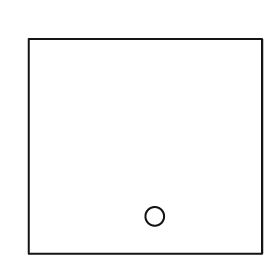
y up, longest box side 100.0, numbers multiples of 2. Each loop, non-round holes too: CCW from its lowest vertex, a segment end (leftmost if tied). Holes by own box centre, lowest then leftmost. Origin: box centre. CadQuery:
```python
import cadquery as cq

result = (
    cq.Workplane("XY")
    .moveTo(-50.0, -46.0)
    .lineTo(50.0, -46.0)
    .lineTo(50.0, 46.0)
    .lineTo(-50.0, 46.0)
    .close()
    .moveTo(4.0, -30.0)
    .circle(4.0)
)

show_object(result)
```